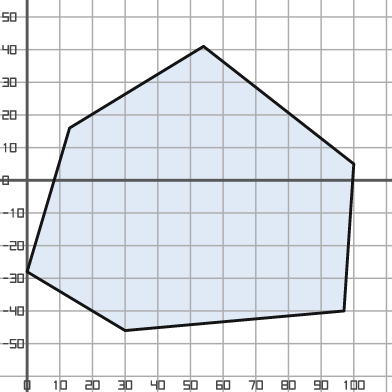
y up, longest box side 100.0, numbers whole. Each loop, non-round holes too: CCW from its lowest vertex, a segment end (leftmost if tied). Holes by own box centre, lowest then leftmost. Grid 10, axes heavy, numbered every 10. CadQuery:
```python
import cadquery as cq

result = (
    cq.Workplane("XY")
    .moveTo(30.0, -46.0)
    .lineTo(97.0, -40.0)
    .lineTo(100.0, 5.0)
    .lineTo(54.0, 41.0)
    .lineTo(13.0, 16.0)
    .lineTo(0.0, -28.0)
    .close()
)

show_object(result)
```